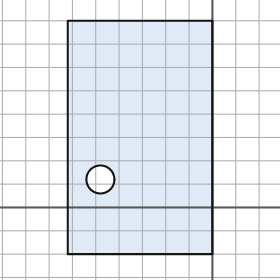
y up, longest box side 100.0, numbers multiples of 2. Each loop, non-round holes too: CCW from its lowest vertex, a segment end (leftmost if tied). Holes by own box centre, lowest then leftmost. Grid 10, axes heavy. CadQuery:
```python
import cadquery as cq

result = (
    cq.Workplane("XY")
    .moveTo(-62.0, -20.0)
    .lineTo(0.0, -20.0)
    .lineTo(0.0, 80.0)
    .lineTo(-62.0, 80.0)
    .close()
    .moveTo(-48.0, 12.0)
    .circle(6.0)
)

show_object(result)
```